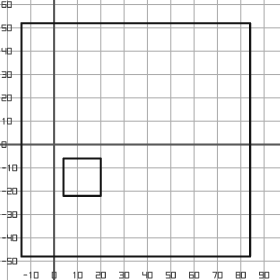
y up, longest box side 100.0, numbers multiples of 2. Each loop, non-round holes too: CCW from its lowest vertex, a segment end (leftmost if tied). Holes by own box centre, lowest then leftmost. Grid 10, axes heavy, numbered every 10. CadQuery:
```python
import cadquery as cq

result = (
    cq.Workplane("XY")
    .moveTo(-14.0, -48.0)
    .lineTo(84.0, -48.0)
    .lineTo(84.0, 52.0)
    .lineTo(-14.0, 52.0)
    .close()
    .moveTo(4.0, -22.0)
    .lineTo(20.0, -22.0)
    .lineTo(20.0, -6.0)
    .lineTo(4.0, -6.0)
    .close()
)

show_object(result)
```